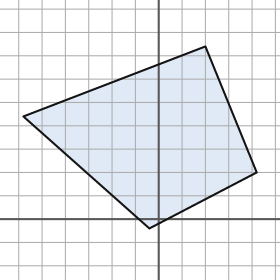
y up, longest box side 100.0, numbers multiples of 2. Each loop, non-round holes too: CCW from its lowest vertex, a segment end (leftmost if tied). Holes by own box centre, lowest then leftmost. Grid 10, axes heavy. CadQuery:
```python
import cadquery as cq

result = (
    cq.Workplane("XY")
    .moveTo(-4.0, -4.0)
    .lineTo(42.0, 20.0)
    .lineTo(20.0, 74.0)
    .lineTo(-58.0, 44.0)
    .close()
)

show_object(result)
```